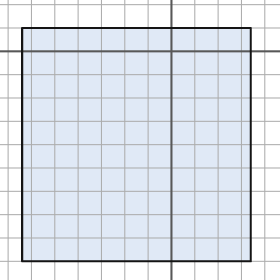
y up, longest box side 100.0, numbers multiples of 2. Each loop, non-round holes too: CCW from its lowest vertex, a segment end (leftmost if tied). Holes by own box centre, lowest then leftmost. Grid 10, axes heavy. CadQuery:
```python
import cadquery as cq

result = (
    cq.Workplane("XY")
    .moveTo(-64.0, -90.0)
    .lineTo(34.0, -90.0)
    .lineTo(34.0, 10.0)
    .lineTo(-64.0, 10.0)
    .close()
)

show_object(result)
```